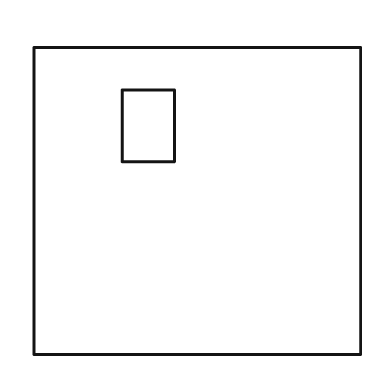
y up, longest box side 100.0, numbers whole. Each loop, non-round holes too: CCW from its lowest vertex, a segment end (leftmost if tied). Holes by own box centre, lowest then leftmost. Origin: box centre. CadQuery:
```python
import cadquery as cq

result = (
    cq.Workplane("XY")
    .moveTo(-50.0, -47.0)
    .lineTo(50.0, -47.0)
    .lineTo(50.0, 47.0)
    .lineTo(-50.0, 47.0)
    .close()
    .moveTo(-23.0, 12.0)
    .lineTo(-7.0, 12.0)
    .lineTo(-7.0, 34.0)
    .lineTo(-23.0, 34.0)
    .close()
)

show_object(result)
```